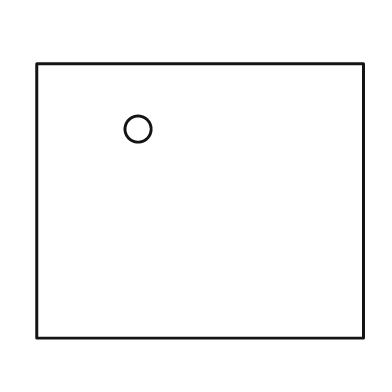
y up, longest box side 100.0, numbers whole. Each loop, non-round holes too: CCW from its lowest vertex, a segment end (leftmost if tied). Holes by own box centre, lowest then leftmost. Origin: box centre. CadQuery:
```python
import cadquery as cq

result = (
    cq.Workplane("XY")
    .moveTo(-50.0, -42.0)
    .lineTo(50.0, -42.0)
    .lineTo(50.0, 42.0)
    .lineTo(-50.0, 42.0)
    .close()
    .moveTo(-19.0, 22.0)
    .circle(4.0)
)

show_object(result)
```